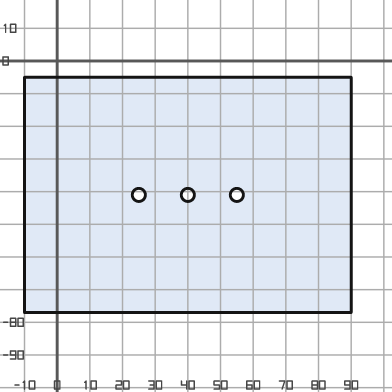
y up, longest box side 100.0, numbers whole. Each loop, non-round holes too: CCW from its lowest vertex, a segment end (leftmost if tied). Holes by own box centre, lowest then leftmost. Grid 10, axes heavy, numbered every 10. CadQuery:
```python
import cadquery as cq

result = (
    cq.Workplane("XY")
    .moveTo(-10.0, -77.0)
    .lineTo(90.0, -77.0)
    .lineTo(90.0, -5.0)
    .lineTo(-10.0, -5.0)
    .close()
    .moveTo(25.0, -41.0)
    .circle(2.0)
    .moveTo(40.0, -41.0)
    .circle(2.0)
    .moveTo(55.0, -41.0)
    .circle(2.0)
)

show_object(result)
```